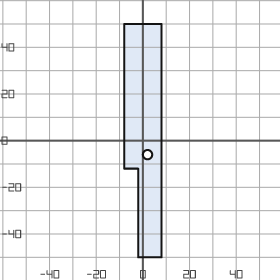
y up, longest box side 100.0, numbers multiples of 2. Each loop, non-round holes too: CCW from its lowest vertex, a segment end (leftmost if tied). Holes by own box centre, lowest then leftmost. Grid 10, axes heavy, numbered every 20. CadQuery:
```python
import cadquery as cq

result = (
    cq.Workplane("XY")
    .moveTo(-2.0, -50.0)
    .lineTo(8.0, -50.0)
    .lineTo(8.0, 50.0)
    .lineTo(-8.0, 50.0)
    .lineTo(-8.0, -12.0)
    .lineTo(-2.0, -12.0)
    .close()
    .moveTo(2.0, -6.0)
    .circle(2.0)
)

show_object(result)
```